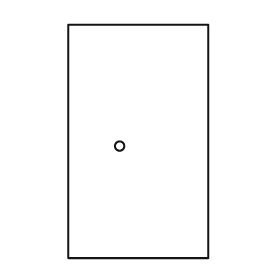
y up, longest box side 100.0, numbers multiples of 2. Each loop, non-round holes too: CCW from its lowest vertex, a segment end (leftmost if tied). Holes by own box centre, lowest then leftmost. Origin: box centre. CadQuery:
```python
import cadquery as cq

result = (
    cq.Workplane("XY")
    .moveTo(-30.0, -50.0)
    .lineTo(30.0, -50.0)
    .lineTo(30.0, 50.0)
    .lineTo(-30.0, 50.0)
    .close()
    .moveTo(-8.0, -2.0)
    .circle(2.0)
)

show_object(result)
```